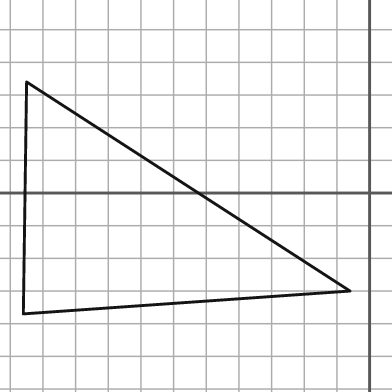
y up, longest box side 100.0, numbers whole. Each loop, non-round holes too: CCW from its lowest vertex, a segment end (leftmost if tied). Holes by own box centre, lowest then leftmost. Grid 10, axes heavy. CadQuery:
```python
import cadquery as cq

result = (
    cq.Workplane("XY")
    .moveTo(-106.0, -37.0)
    .lineTo(-6.0, -30.0)
    .lineTo(-105.0, 34.0)
    .close()
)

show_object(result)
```